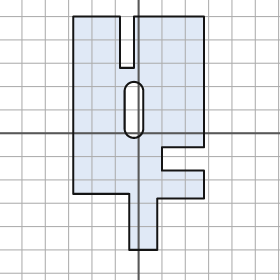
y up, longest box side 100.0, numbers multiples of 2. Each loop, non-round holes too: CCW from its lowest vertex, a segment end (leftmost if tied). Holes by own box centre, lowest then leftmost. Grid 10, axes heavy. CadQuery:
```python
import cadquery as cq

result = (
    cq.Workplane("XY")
    .moveTo(-4.0, -50.0)
    .lineTo(8.0, -50.0)
    .lineTo(8.0, -28.0)
    .lineTo(28.0, -28.0)
    .lineTo(28.0, -16.0)
    .lineTo(10.0, -16.0)
    .lineTo(10.0, -6.0)
    .lineTo(28.0, -6.0)
    .lineTo(28.0, 50.0)
    .lineTo(-2.0, 50.0)
    .lineTo(-2.0, 28.0)
    .lineTo(-8.0, 28.0)
    .lineTo(-8.0, 50.0)
    .lineTo(-28.0, 50.0)
    .lineTo(-28.0, -26.0)
    .lineTo(-4.0, -26.0)
    .close()
    .moveTo(-6.0, 2.0)
    .threePointArc((-2.0, -2.0), (2.0, 2.0))
    .lineTo(2.0, 18.0)
    .threePointArc((-2.0, 22.0), (-6.0, 18.0))
    .close()
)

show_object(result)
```